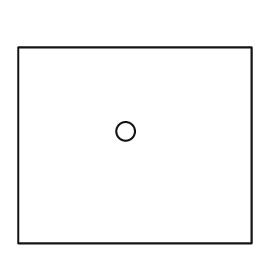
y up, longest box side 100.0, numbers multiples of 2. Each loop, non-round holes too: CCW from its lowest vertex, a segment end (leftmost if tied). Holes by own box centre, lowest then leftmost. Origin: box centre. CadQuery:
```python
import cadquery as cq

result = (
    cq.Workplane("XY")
    .moveTo(-50.0, -42.0)
    .lineTo(50.0, -42.0)
    .lineTo(50.0, 42.0)
    .lineTo(-50.0, 42.0)
    .close()
    .moveTo(-4.0, 6.0)
    .circle(4.0)
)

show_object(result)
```